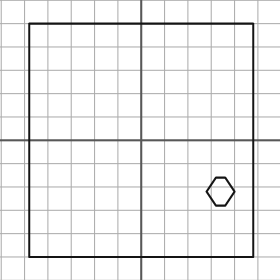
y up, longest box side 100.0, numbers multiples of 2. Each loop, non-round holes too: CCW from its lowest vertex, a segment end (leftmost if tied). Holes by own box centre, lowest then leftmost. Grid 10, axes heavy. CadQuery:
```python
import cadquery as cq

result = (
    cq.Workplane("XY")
    .moveTo(-48.0, -50.0)
    .lineTo(48.0, -50.0)
    .lineTo(48.0, 50.0)
    .lineTo(-48.0, 50.0)
    .close()
    .moveTo(32.0, -28.0)
    .lineTo(36.0, -28.0)
    .lineTo(40.0, -22.0)
    .lineTo(36.0, -16.0)
    .lineTo(32.0, -16.0)
    .lineTo(28.0, -22.0)
    .close()
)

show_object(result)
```